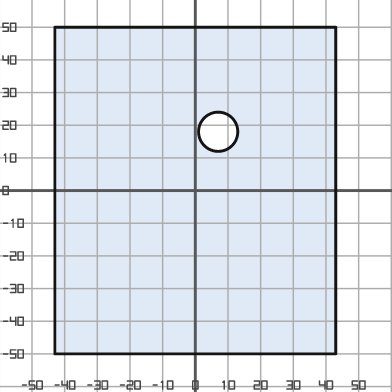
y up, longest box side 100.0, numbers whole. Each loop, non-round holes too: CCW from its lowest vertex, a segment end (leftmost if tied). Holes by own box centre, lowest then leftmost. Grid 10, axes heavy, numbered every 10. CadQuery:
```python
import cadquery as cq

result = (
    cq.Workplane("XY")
    .moveTo(-43.0, -50.0)
    .lineTo(43.0, -50.0)
    .lineTo(43.0, 50.0)
    .lineTo(-43.0, 50.0)
    .close()
    .moveTo(7.0, 18.0)
    .circle(6.0)
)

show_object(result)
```